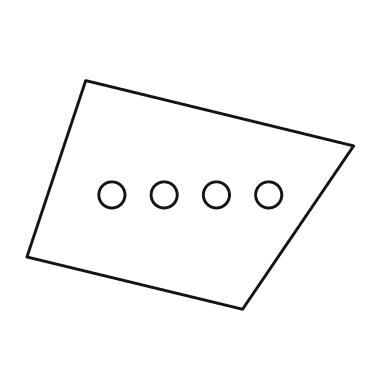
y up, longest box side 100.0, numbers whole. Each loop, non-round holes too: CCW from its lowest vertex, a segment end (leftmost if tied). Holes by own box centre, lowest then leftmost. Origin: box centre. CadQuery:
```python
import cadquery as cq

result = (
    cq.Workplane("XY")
    .moveTo(16.0, -35.0)
    .lineTo(50.0, 15.0)
    .lineTo(-32.0, 35.0)
    .lineTo(-50.0, -19.0)
    .close()
    .moveTo(-24.0, 0.0)
    .circle(4.0)
    .moveTo(-8.0, 0.0)
    .circle(4.0)
    .moveTo(8.0, 0.0)
    .circle(4.0)
    .moveTo(24.0, 0.0)
    .circle(4.0)
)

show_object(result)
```